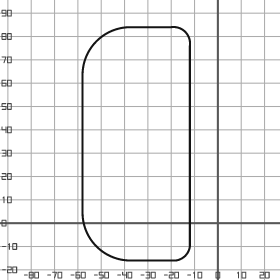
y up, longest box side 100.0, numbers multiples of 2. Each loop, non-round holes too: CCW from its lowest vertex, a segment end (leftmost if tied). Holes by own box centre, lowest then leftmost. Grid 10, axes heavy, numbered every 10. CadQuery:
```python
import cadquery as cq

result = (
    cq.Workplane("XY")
    .moveTo(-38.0, -16.0)
    .lineTo(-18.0, -16.0)
    .threePointArc((-14.0, -14.0), (-12.0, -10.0))
    .lineTo(-12.0, 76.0)
    .threePointArc((-14.0, 82.0), (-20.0, 84.0))
    .lineTo(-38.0, 84.0)
    .threePointArc((-52.0, 78.0), (-58.0, 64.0))
    .lineTo(-58.0, 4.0)
    .threePointArc((-52.0, -10.0), (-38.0, -16.0))
    .close()
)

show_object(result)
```